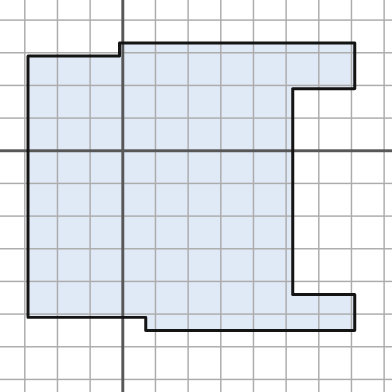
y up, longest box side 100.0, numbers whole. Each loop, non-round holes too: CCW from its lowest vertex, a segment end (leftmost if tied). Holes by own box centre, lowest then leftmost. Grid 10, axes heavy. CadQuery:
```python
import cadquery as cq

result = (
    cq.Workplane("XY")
    .moveTo(7.0, -55.0)
    .lineTo(71.0, -55.0)
    .lineTo(71.0, -44.0)
    .lineTo(52.0, -44.0)
    .lineTo(52.0, 19.0)
    .lineTo(71.0, 19.0)
    .lineTo(71.0, 33.0)
    .lineTo(-1.0, 33.0)
    .lineTo(-1.0, 29.0)
    .lineTo(-29.0, 29.0)
    .lineTo(-29.0, -51.0)
    .lineTo(7.0, -51.0)
    .close()
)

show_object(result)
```